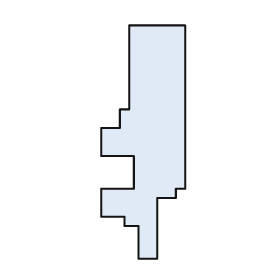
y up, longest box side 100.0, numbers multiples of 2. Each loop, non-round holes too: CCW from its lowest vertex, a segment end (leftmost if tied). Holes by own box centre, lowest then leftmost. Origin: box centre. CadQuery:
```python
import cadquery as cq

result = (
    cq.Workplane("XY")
    .moveTo(-2.0, -50.0)
    .lineTo(6.0, -50.0)
    .lineTo(6.0, -24.0)
    .lineTo(14.0, -24.0)
    .lineTo(14.0, -20.0)
    .lineTo(18.0, -20.0)
    .lineTo(18.0, 50.0)
    .lineTo(-6.0, 50.0)
    .lineTo(-6.0, 14.0)
    .lineTo(-10.0, 14.0)
    .lineTo(-10.0, 6.0)
    .lineTo(-18.0, 6.0)
    .lineTo(-18.0, -6.0)
    .lineTo(-4.0, -6.0)
    .lineTo(-4.0, -20.0)
    .lineTo(-18.0, -20.0)
    .lineTo(-18.0, -32.0)
    .lineTo(-8.0, -32.0)
    .lineTo(-8.0, -36.0)
    .lineTo(-2.0, -36.0)
    .close()
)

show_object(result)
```